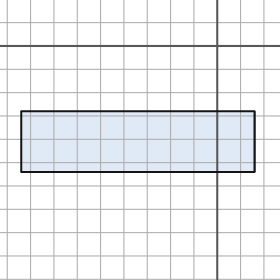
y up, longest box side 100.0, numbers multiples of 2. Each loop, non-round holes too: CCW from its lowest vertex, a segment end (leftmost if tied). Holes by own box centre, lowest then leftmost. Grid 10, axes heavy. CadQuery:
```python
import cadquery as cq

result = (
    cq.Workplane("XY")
    .moveTo(-84.0, -54.0)
    .lineTo(16.0, -54.0)
    .lineTo(16.0, -28.0)
    .lineTo(-84.0, -28.0)
    .close()
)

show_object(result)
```